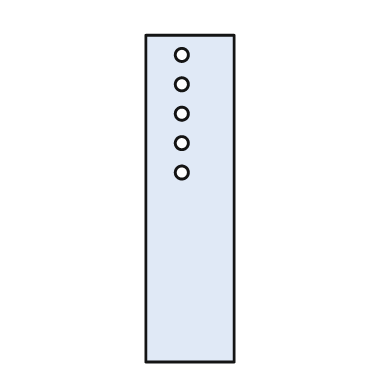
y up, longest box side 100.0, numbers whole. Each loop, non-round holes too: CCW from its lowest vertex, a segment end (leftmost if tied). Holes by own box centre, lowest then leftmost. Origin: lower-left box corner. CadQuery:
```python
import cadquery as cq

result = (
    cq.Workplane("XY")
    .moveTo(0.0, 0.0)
    .lineTo(27.0, 0.0)
    .lineTo(27.0, 100.0)
    .lineTo(0.0, 100.0)
    .close()
    .moveTo(11.0, 58.0)
    .circle(2.0)
    .moveTo(11.0, 67.0)
    .circle(2.0)
    .moveTo(11.0, 76.0)
    .circle(2.0)
    .moveTo(11.0, 85.0)
    .circle(2.0)
    .moveTo(11.0, 94.0)
    .circle(2.0)
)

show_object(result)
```